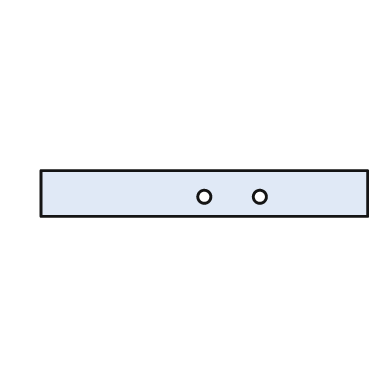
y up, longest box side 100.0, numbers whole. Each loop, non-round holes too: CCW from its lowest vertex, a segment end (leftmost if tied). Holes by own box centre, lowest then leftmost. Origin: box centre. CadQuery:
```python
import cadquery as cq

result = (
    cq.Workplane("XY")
    .moveTo(-50.0, -7.0)
    .lineTo(50.0, -7.0)
    .lineTo(50.0, 7.0)
    .lineTo(-50.0, 7.0)
    .close()
    .moveTo(0.0, -1.0)
    .circle(2.0)
    .moveTo(17.0, -1.0)
    .circle(2.0)
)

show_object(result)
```